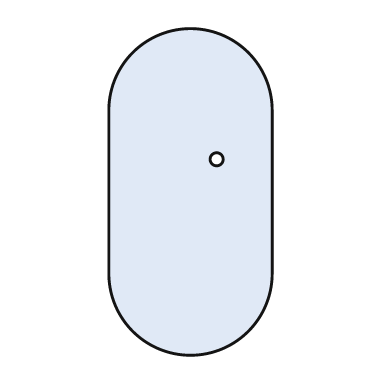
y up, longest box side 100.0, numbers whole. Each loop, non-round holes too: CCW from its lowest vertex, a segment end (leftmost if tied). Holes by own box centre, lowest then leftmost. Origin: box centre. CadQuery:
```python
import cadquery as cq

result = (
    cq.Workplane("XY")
    .moveTo(-25.0, -25.0)
    .threePointArc((0.0, -50.0), (25.0, -25.0))
    .lineTo(25.0, 25.0)
    .threePointArc((0.0, 50.0), (-25.0, 25.0))
    .close()
    .moveTo(8.0, 10.0)
    .circle(2.0)
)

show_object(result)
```